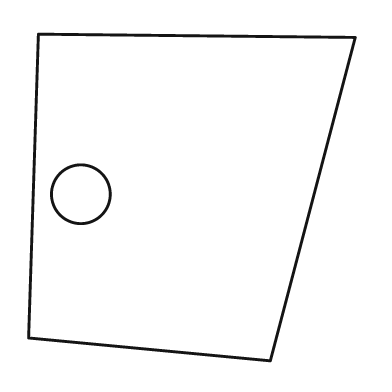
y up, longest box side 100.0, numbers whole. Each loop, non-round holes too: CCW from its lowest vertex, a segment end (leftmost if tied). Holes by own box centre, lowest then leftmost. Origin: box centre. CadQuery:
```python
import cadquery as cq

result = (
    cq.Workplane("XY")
    .moveTo(24.0, -50.0)
    .lineTo(50.0, 49.0)
    .lineTo(-47.0, 50.0)
    .lineTo(-50.0, -43.0)
    .close()
    .moveTo(-34.0, 1.0)
    .circle(9.0)
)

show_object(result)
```